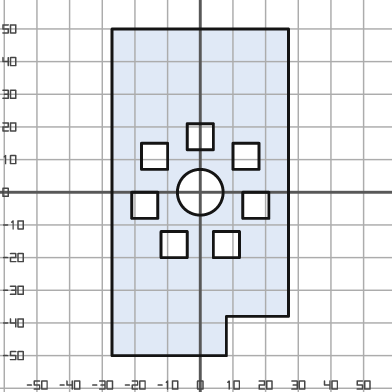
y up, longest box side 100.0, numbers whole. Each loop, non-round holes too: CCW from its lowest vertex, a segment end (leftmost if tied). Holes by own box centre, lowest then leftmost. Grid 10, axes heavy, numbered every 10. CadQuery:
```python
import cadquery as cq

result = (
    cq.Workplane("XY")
    .moveTo(-27.0, -50.0)
    .lineTo(8.0, -50.0)
    .lineTo(8.0, -38.0)
    .lineTo(27.0, -38.0)
    .lineTo(27.0, 50.0)
    .lineTo(-27.0, 50.0)
    .close()
    .moveTo(-12.0, -20.0)
    .lineTo(-4.0, -20.0)
    .lineTo(-4.0, -12.0)
    .lineTo(-12.0, -12.0)
    .close()
    .moveTo(4.0, -20.0)
    .lineTo(12.0, -20.0)
    .lineTo(12.0, -12.0)
    .lineTo(4.0, -12.0)
    .close()
    .moveTo(-21.0, -8.0)
    .lineTo(-13.0, -8.0)
    .lineTo(-13.0, 0.0)
    .lineTo(-21.0, 0.0)
    .close()
    .moveTo(13.0, -8.0)
    .lineTo(21.0, -8.0)
    .lineTo(21.0, 0.0)
    .lineTo(13.0, 0.0)
    .close()
    .moveTo(0.0, 0.0)
    .circle(7.0)
    .moveTo(-18.0, 7.0)
    .lineTo(-10.0, 7.0)
    .lineTo(-10.0, 15.0)
    .lineTo(-18.0, 15.0)
    .close()
    .moveTo(10.0, 7.0)
    .lineTo(18.0, 7.0)
    .lineTo(18.0, 15.0)
    .lineTo(10.0, 15.0)
    .close()
    .moveTo(-4.0, 13.0)
    .lineTo(4.0, 13.0)
    .lineTo(4.0, 21.0)
    .lineTo(-4.0, 21.0)
    .close()
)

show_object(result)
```